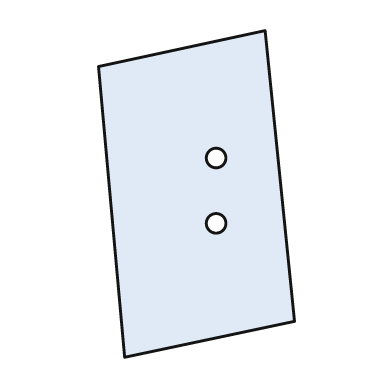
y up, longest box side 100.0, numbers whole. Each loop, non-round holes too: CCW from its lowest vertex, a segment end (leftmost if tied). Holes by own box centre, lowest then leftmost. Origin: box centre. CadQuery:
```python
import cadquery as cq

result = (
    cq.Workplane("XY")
    .moveTo(-22.0, -50.0)
    .lineTo(30.0, -39.0)
    .lineTo(21.0, 50.0)
    .lineTo(-30.0, 39.0)
    .close()
    .moveTo(6.0, -9.0)
    .circle(3.0)
    .moveTo(6.0, 11.0)
    .circle(3.0)
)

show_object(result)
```